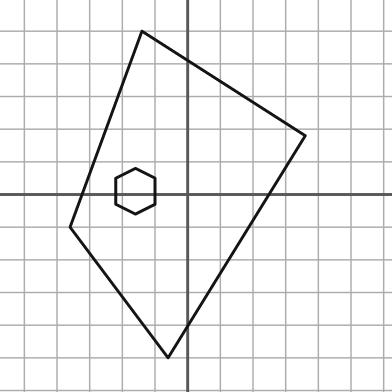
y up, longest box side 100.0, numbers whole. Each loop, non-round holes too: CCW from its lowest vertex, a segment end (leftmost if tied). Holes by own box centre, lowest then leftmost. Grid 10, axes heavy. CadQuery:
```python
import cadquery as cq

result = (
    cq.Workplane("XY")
    .moveTo(-6.0, -50.0)
    .lineTo(36.0, 18.0)
    .lineTo(-14.0, 50.0)
    .lineTo(-36.0, -10.0)
    .close()
    .moveTo(-16.0, -6.0)
    .lineTo(-10.0, -3.0)
    .lineTo(-10.0, 5.0)
    .lineTo(-16.0, 8.0)
    .lineTo(-22.0, 5.0)
    .lineTo(-22.0, -3.0)
    .close()
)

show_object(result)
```